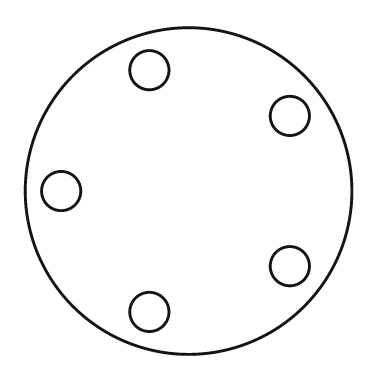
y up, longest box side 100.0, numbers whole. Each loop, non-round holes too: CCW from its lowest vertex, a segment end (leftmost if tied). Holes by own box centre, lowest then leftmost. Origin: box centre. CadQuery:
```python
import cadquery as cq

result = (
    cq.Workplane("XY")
    .moveTo(0.0, 0.0)
    .circle(50.0)
    .moveTo(-12.0, -37.0)
    .circle(6.0)
    .moveTo(31.0, -23.0)
    .circle(6.0)
    .moveTo(-39.0, 0.0)
    .circle(6.0)
    .moveTo(31.0, 23.0)
    .circle(6.0)
    .moveTo(-12.0, 37.0)
    .circle(6.0)
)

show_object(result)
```